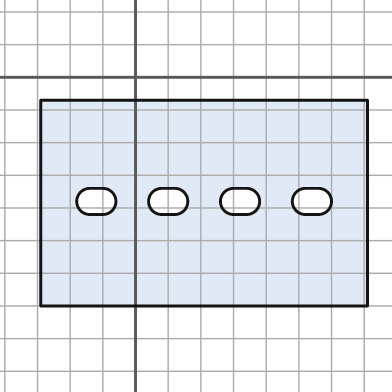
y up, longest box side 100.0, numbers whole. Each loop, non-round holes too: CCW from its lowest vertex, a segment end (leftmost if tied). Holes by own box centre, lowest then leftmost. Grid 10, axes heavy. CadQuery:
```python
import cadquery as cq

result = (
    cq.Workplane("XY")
    .moveTo(-29.0, -70.0)
    .lineTo(71.0, -70.0)
    .lineTo(71.0, -7.0)
    .lineTo(-29.0, -7.0)
    .close()
    .moveTo(-14.0, -42.0)
    .lineTo(-10.0, -42.0)
    .threePointArc((-6.0, -38.0), (-10.0, -34.0))
    .lineTo(-14.0, -34.0)
    .threePointArc((-18.0, -38.0), (-14.0, -42.0))
    .close()
    .moveTo(8.0, -42.0)
    .lineTo(12.0, -42.0)
    .threePointArc((16.0, -38.0), (12.0, -34.0))
    .lineTo(8.0, -34.0)
    .threePointArc((4.0, -38.0), (8.0, -42.0))
    .close()
    .moveTo(30.0, -42.0)
    .lineTo(34.0, -42.0)
    .threePointArc((38.0, -38.0), (34.0, -34.0))
    .lineTo(30.0, -34.0)
    .threePointArc((26.0, -38.0), (30.0, -42.0))
    .close()
    .moveTo(52.0, -42.0)
    .lineTo(56.0, -42.0)
    .threePointArc((60.0, -38.0), (56.0, -34.0))
    .lineTo(52.0, -34.0)
    .threePointArc((48.0, -38.0), (52.0, -42.0))
    .close()
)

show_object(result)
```